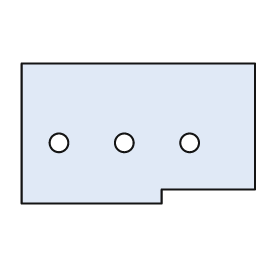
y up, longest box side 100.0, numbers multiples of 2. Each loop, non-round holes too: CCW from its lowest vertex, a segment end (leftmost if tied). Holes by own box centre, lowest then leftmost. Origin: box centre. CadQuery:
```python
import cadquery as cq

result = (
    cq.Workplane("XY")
    .moveTo(-50.0, -30.0)
    .lineTo(10.0, -30.0)
    .lineTo(10.0, -24.0)
    .lineTo(50.0, -24.0)
    .lineTo(50.0, 30.0)
    .lineTo(-50.0, 30.0)
    .close()
    .moveTo(-34.0, -4.0)
    .circle(4.0)
    .moveTo(-6.0, -4.0)
    .circle(4.0)
    .moveTo(22.0, -4.0)
    .circle(4.0)
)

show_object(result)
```